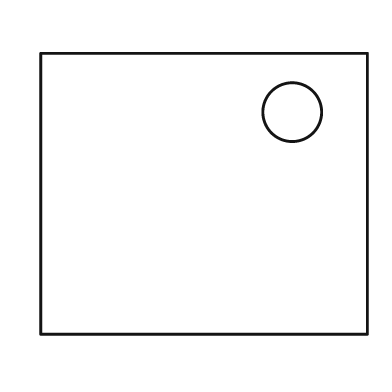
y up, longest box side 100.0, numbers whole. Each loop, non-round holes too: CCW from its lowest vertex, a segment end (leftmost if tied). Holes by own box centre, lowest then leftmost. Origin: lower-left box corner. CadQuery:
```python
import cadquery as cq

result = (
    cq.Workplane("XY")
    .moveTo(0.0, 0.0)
    .lineTo(100.0, 0.0)
    .lineTo(100.0, 86.0)
    .lineTo(0.0, 86.0)
    .close()
    .moveTo(77.0, 68.0)
    .circle(9.0)
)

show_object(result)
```